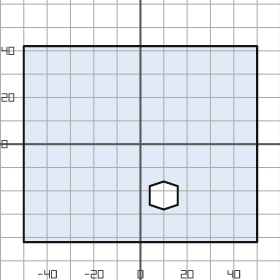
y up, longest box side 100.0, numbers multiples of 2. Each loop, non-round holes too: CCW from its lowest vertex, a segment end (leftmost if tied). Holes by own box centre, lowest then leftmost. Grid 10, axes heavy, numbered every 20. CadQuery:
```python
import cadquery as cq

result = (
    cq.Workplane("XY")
    .moveTo(-50.0, -42.0)
    .lineTo(50.0, -42.0)
    .lineTo(50.0, 42.0)
    .lineTo(-50.0, 42.0)
    .close()
    .moveTo(10.0, -28.0)
    .lineTo(16.0, -26.0)
    .lineTo(16.0, -18.0)
    .lineTo(10.0, -16.0)
    .lineTo(4.0, -18.0)
    .lineTo(4.0, -26.0)
    .close()
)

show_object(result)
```